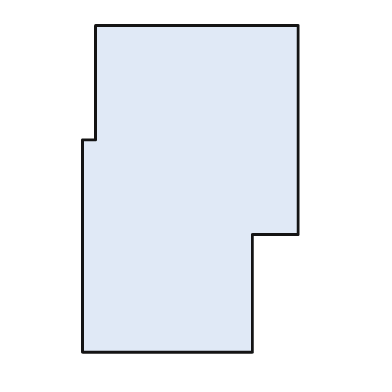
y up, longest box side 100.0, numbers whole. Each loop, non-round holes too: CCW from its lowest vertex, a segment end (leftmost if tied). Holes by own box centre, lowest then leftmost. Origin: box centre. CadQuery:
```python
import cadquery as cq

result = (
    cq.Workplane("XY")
    .moveTo(-33.0, -50.0)
    .lineTo(19.0, -50.0)
    .lineTo(19.0, -14.0)
    .lineTo(33.0, -14.0)
    .lineTo(33.0, 50.0)
    .lineTo(-29.0, 50.0)
    .lineTo(-29.0, 15.0)
    .lineTo(-33.0, 15.0)
    .close()
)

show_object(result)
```